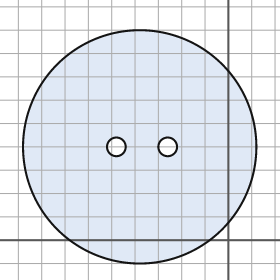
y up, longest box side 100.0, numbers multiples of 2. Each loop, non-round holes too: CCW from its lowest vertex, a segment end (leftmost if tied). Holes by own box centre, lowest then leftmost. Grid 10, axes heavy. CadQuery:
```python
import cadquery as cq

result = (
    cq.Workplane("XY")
    .moveTo(-38.0, 40.0)
    .circle(50.0)
    .moveTo(-48.0, 40.0)
    .circle(4.0)
    .moveTo(-26.0, 40.0)
    .circle(4.0)
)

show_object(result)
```